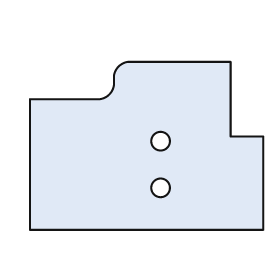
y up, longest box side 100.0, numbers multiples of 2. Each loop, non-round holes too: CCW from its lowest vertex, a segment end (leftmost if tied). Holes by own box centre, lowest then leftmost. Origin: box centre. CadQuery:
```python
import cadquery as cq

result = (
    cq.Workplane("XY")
    .moveTo(-50.0, -36.0)
    .lineTo(50.0, -36.0)
    .lineTo(50.0, 4.0)
    .lineTo(36.0, 4.0)
    .lineTo(36.0, 36.0)
    .lineTo(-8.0, 36.0)
    .threePointArc((-12.0, 34.0), (-14.0, 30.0))
    .lineTo(-14.0, 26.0)
    .threePointArc((-16.0, 22.0), (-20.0, 20.0))
    .lineTo(-50.0, 20.0)
    .close()
    .moveTo(6.0, -18.0)
    .circle(4.0)
    .moveTo(6.0, 2.0)
    .circle(4.0)
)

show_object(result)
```